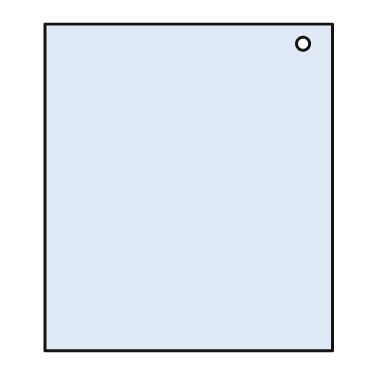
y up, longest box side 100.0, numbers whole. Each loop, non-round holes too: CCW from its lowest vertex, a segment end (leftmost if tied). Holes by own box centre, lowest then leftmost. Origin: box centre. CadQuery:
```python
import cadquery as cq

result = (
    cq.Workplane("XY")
    .moveTo(-44.0, -50.0)
    .lineTo(44.0, -50.0)
    .lineTo(44.0, 50.0)
    .lineTo(-44.0, 50.0)
    .close()
    .moveTo(35.0, 44.0)
    .circle(2.0)
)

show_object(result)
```